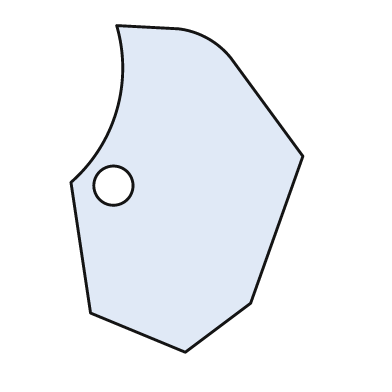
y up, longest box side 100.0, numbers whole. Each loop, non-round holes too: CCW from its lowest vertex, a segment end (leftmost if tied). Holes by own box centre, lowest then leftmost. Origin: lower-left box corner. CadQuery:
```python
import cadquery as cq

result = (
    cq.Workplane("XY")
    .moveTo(35.0, 0.0)
    .lineTo(55.0, 15.0)
    .lineTo(71.0, 60.0)
    .lineTo(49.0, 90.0)
    .threePointArc((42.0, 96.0), (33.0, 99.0))
    .lineTo(14.0, 100.0)
    .threePointArc((14.0, 74.0), (0.0, 52.0))
    .lineTo(6.0, 12.0)
    .close()
    .moveTo(13.0, 51.0)
    .circle(6.0)
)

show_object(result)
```